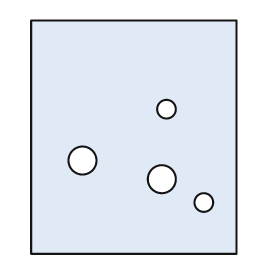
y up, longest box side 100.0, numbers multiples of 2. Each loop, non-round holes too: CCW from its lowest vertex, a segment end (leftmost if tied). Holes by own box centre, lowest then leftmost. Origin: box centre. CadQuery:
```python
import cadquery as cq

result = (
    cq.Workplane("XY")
    .moveTo(-44.0, -50.0)
    .lineTo(44.0, -50.0)
    .lineTo(44.0, 50.0)
    .lineTo(-44.0, 50.0)
    .close()
    .moveTo(30.0, -28.0)
    .circle(4.0)
    .moveTo(12.0, -18.0)
    .circle(6.0)
    .moveTo(-22.0, -10.0)
    .circle(6.0)
    .moveTo(14.0, 12.0)
    .circle(4.0)
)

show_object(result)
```